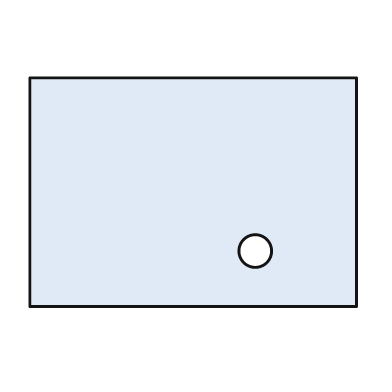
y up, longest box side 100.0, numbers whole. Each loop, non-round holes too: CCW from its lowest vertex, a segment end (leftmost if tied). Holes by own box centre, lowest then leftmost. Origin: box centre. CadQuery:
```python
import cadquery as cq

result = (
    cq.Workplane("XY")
    .moveTo(-50.0, -35.0)
    .lineTo(50.0, -35.0)
    .lineTo(50.0, 35.0)
    .lineTo(-50.0, 35.0)
    .close()
    .moveTo(19.0, -18.0)
    .circle(5.0)
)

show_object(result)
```